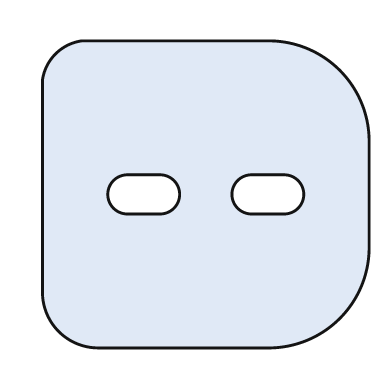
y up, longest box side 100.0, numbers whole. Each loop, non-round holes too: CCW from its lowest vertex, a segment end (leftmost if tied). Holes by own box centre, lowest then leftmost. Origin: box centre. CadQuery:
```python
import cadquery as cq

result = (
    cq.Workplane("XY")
    .moveTo(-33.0, -47.0)
    .lineTo(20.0, -47.0)
    .threePointArc((41.0, -38.0), (50.0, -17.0))
    .lineTo(50.0, 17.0)
    .threePointArc((41.0, 38.0), (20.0, 47.0))
    .lineTo(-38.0, 47.0)
    .threePointArc((-46.0, 43.0), (-50.0, 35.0))
    .lineTo(-50.0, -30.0)
    .threePointArc((-45.0, -42.0), (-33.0, -47.0))
    .close()
    .moveTo(-24.0, -6.0)
    .lineTo(-14.0, -6.0)
    .threePointArc((-8.0, 0.0), (-14.0, 6.0))
    .lineTo(-24.0, 6.0)
    .threePointArc((-30.0, 0.0), (-24.0, -6.0))
    .close()
    .moveTo(14.0, -6.0)
    .lineTo(24.0, -6.0)
    .threePointArc((30.0, 0.0), (24.0, 6.0))
    .lineTo(14.0, 6.0)
    .threePointArc((8.0, 0.0), (14.0, -6.0))
    .close()
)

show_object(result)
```